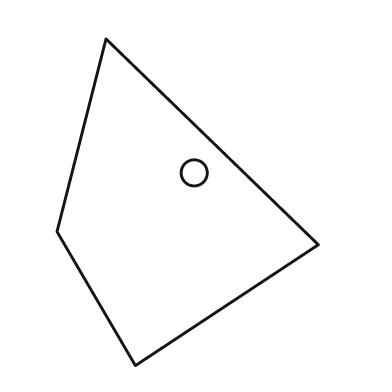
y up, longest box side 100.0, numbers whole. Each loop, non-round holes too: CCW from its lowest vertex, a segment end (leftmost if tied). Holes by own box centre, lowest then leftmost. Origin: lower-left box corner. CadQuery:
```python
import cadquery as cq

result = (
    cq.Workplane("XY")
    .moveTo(24.0, 0.0)
    .lineTo(80.0, 37.0)
    .lineTo(15.0, 100.0)
    .lineTo(0.0, 41.0)
    .close()
    .moveTo(42.0, 59.0)
    .circle(4.0)
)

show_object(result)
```